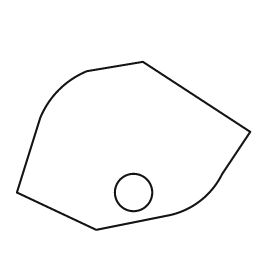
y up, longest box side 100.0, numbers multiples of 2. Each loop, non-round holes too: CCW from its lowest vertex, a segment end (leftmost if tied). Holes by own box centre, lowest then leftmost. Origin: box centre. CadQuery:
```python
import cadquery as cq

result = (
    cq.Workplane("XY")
    .moveTo(-16.0, -36.0)
    .lineTo(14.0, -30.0)
    .threePointArc((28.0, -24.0), (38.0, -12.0))
    .lineTo(50.0, 6.0)
    .lineTo(4.0, 36.0)
    .lineTo(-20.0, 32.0)
    .threePointArc((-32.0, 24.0), (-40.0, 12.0))
    .lineTo(-50.0, -20.0)
    .close()
    .moveTo(0.0, -20.0)
    .circle(8.0)
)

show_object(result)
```